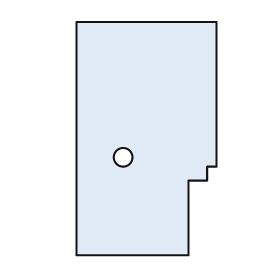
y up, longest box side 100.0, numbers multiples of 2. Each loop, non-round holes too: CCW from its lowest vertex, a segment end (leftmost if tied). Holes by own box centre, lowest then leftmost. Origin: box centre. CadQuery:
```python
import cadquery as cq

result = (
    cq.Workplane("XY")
    .moveTo(-30.0, -50.0)
    .lineTo(18.0, -50.0)
    .lineTo(18.0, -18.0)
    .lineTo(26.0, -18.0)
    .lineTo(26.0, -12.0)
    .lineTo(30.0, -12.0)
    .lineTo(30.0, 50.0)
    .lineTo(-30.0, 50.0)
    .close()
    .moveTo(-10.0, -8.0)
    .circle(4.0)
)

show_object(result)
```